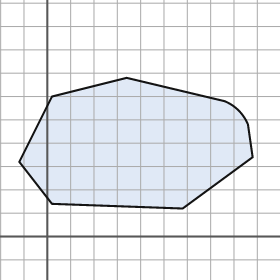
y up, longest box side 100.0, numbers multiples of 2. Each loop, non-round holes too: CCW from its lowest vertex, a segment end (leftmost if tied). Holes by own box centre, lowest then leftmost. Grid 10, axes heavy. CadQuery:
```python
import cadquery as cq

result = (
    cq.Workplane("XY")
    .moveTo(58.0, 12.0)
    .lineTo(88.0, 34.0)
    .lineTo(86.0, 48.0)
    .threePointArc((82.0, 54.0), (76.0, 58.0))
    .lineTo(34.0, 68.0)
    .lineTo(2.0, 60.0)
    .lineTo(-12.0, 32.0)
    .lineTo(2.0, 14.0)
    .close()
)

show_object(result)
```